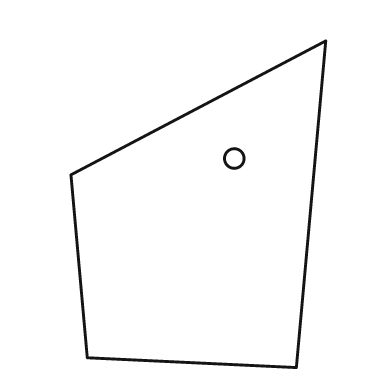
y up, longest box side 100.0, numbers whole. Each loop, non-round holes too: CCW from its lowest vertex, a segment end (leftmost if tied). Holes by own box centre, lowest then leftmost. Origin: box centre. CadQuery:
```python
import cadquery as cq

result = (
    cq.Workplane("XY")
    .moveTo(30.0, -50.0)
    .lineTo(39.0, 50.0)
    .lineTo(-39.0, 9.0)
    .lineTo(-34.0, -47.0)
    .close()
    .moveTo(11.0, 14.0)
    .circle(3.0)
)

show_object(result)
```